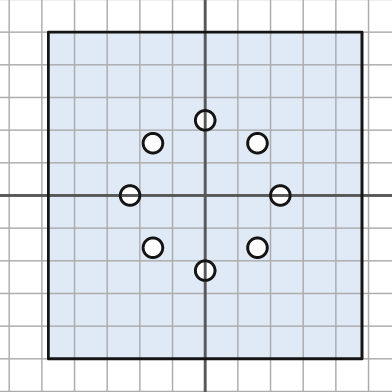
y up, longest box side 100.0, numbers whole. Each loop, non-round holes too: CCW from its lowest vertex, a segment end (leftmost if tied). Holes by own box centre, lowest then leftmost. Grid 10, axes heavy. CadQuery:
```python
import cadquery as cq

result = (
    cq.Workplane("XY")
    .moveTo(-48.0, -50.0)
    .lineTo(48.0, -50.0)
    .lineTo(48.0, 50.0)
    .lineTo(-48.0, 50.0)
    .close()
    .moveTo(0.0, -23.0)
    .circle(3.0)
    .moveTo(-16.0, -16.0)
    .circle(3.0)
    .moveTo(16.0, -16.0)
    .circle(3.0)
    .moveTo(-23.0, 0.0)
    .circle(3.0)
    .moveTo(23.0, 0.0)
    .circle(3.0)
    .moveTo(-16.0, 16.0)
    .circle(3.0)
    .moveTo(16.0, 16.0)
    .circle(3.0)
    .moveTo(0.0, 23.0)
    .circle(3.0)
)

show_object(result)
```